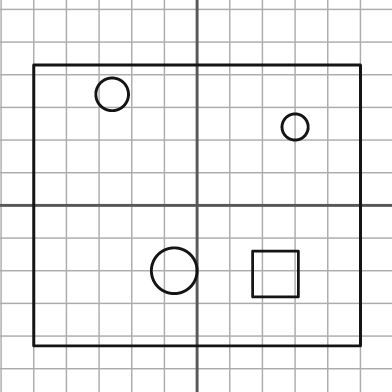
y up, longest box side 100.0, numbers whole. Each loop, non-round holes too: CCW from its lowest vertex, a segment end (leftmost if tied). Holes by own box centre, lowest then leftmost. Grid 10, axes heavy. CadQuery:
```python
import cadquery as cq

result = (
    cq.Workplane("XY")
    .moveTo(-50.0, -43.0)
    .lineTo(50.0, -43.0)
    .lineTo(50.0, 43.0)
    .lineTo(-50.0, 43.0)
    .close()
    .moveTo(17.0, -28.0)
    .lineTo(31.0, -28.0)
    .lineTo(31.0, -14.0)
    .lineTo(17.0, -14.0)
    .close()
    .moveTo(-7.0, -20.0)
    .circle(7.0)
    .moveTo(30.0, 24.0)
    .circle(4.0)
    .moveTo(-26.0, 34.0)
    .circle(5.0)
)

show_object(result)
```